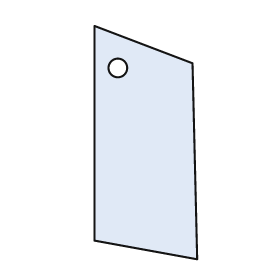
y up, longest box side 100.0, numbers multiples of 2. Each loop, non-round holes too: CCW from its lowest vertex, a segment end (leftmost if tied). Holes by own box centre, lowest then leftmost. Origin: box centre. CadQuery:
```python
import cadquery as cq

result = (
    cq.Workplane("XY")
    .moveTo(22.0, -50.0)
    .lineTo(20.0, 34.0)
    .lineTo(-22.0, 50.0)
    .lineTo(-22.0, -42.0)
    .close()
    .moveTo(-12.0, 32.0)
    .circle(4.0)
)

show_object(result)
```